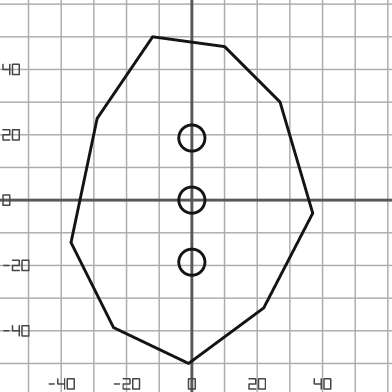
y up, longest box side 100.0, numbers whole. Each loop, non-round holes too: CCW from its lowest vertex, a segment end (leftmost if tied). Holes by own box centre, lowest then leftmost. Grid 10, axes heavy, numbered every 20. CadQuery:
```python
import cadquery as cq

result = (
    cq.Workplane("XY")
    .moveTo(-1.0, -50.0)
    .lineTo(22.0, -33.0)
    .lineTo(37.0, -4.0)
    .lineTo(27.0, 30.0)
    .lineTo(10.0, 47.0)
    .lineTo(-12.0, 50.0)
    .lineTo(-29.0, 25.0)
    .lineTo(-37.0, -13.0)
    .lineTo(-24.0, -39.0)
    .close()
    .moveTo(0.0, -19.0)
    .circle(4.0)
    .moveTo(0.0, 0.0)
    .circle(4.0)
    .moveTo(0.0, 19.0)
    .circle(4.0)
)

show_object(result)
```